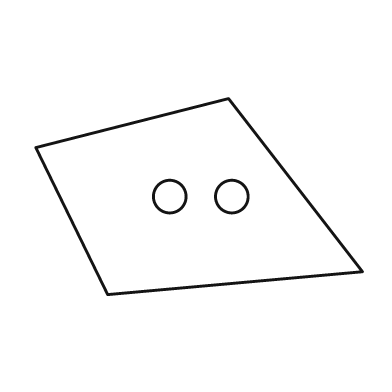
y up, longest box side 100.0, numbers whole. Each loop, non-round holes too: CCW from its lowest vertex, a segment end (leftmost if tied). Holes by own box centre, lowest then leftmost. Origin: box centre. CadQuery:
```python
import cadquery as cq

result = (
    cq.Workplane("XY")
    .moveTo(-28.0, -30.0)
    .lineTo(50.0, -23.0)
    .lineTo(9.0, 30.0)
    .lineTo(-50.0, 15.0)
    .close()
    .moveTo(-9.0, 0.0)
    .circle(5.0)
    .moveTo(10.0, 0.0)
    .circle(5.0)
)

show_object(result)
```